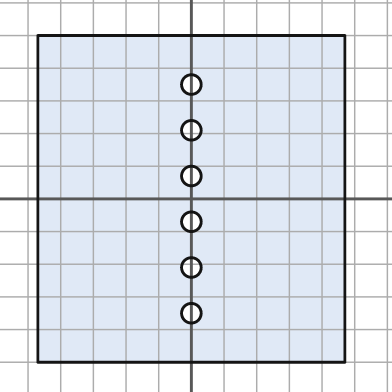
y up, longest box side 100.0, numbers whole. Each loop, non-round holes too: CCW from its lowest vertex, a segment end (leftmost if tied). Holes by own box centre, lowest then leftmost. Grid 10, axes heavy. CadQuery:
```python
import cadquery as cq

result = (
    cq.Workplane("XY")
    .moveTo(-47.0, -50.0)
    .lineTo(47.0, -50.0)
    .lineTo(47.0, 50.0)
    .lineTo(-47.0, 50.0)
    .close()
    .moveTo(0.0, -35.0)
    .circle(3.0)
    .moveTo(0.0, -21.0)
    .circle(3.0)
    .moveTo(0.0, -7.0)
    .circle(3.0)
    .moveTo(0.0, 7.0)
    .circle(3.0)
    .moveTo(0.0, 21.0)
    .circle(3.0)
    .moveTo(0.0, 35.0)
    .circle(3.0)
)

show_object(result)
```